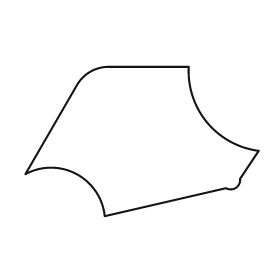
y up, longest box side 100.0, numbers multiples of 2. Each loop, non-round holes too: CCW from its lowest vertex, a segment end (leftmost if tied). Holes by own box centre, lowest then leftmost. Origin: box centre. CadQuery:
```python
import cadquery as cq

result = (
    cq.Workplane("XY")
    .moveTo(-16.0, -32.0)
    .lineTo(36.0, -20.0)
    .threePointArc((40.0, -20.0), (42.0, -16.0))
    .lineTo(50.0, -4.0)
    .threePointArc((28.0, 8.0), (20.0, 32.0))
    .lineTo(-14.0, 32.0)
    .threePointArc((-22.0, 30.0), (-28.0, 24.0))
    .lineTo(-50.0, -14.0)
    .threePointArc((-28.0, -14.0), (-16.0, -32.0))
    .close()
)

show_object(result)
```